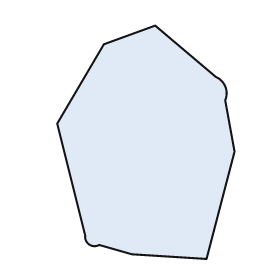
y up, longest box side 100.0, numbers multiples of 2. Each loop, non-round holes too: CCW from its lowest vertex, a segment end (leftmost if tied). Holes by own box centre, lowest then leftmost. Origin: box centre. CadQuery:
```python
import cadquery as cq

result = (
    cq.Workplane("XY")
    .moveTo(26.0, -50.0)
    .lineTo(38.0, -4.0)
    .lineTo(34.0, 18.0)
    .threePointArc((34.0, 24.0), (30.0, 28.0))
    .lineTo(4.0, 50.0)
    .lineTo(-18.0, 42.0)
    .lineTo(-38.0, 8.0)
    .lineTo(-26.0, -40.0)
    .threePointArc((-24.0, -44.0), (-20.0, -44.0))
    .lineTo(-6.0, -48.0)
    .close()
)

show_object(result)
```